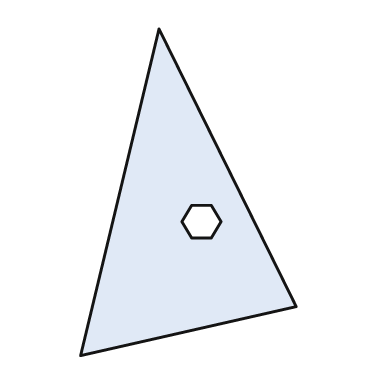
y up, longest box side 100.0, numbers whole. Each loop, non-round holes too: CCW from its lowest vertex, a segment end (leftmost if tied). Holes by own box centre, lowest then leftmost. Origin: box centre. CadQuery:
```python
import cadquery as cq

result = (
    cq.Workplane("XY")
    .moveTo(-33.0, -50.0)
    .lineTo(33.0, -35.0)
    .lineTo(-9.0, 50.0)
    .close()
    .moveTo(1.0, -14.0)
    .lineTo(7.0, -14.0)
    .lineTo(10.0, -9.0)
    .lineTo(7.0, -4.0)
    .lineTo(1.0, -4.0)
    .lineTo(-2.0, -9.0)
    .close()
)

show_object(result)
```